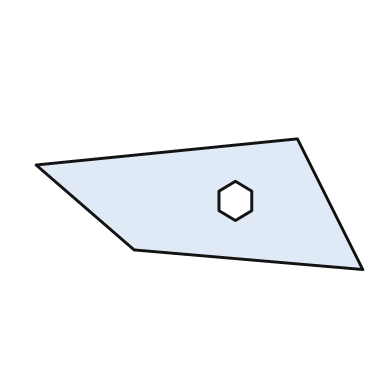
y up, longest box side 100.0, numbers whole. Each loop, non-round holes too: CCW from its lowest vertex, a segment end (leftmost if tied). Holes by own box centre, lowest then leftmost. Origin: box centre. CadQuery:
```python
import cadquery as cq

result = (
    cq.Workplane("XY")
    .moveTo(50.0, -20.0)
    .lineTo(30.0, 20.0)
    .lineTo(-50.0, 12.0)
    .lineTo(-20.0, -14.0)
    .close()
    .moveTo(11.0, -5.0)
    .lineTo(16.0, -2.0)
    .lineTo(16.0, 4.0)
    .lineTo(11.0, 7.0)
    .lineTo(6.0, 4.0)
    .lineTo(6.0, -2.0)
    .close()
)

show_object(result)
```